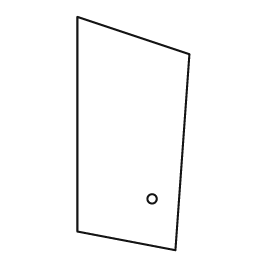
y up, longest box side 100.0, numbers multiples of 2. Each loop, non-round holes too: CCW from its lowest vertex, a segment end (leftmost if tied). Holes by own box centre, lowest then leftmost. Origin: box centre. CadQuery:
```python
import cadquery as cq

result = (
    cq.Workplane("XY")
    .moveTo(18.0, -50.0)
    .lineTo(24.0, 34.0)
    .lineTo(-24.0, 50.0)
    .lineTo(-24.0, -42.0)
    .close()
    .moveTo(8.0, -28.0)
    .circle(2.0)
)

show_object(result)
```